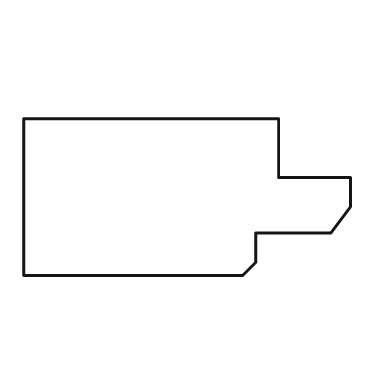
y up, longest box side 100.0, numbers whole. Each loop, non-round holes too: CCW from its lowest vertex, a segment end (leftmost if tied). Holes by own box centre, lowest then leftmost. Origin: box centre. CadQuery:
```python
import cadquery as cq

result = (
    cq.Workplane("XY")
    .moveTo(-50.0, -24.0)
    .lineTo(17.0, -24.0)
    .lineTo(21.0, -20.0)
    .lineTo(21.0, -11.0)
    .lineTo(44.0, -11.0)
    .lineTo(50.0, -3.0)
    .lineTo(50.0, 6.0)
    .lineTo(28.0, 6.0)
    .lineTo(28.0, 24.0)
    .lineTo(-50.0, 24.0)
    .close()
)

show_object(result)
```